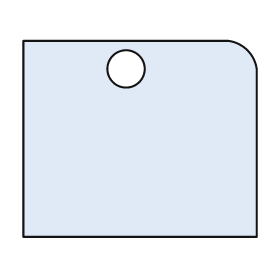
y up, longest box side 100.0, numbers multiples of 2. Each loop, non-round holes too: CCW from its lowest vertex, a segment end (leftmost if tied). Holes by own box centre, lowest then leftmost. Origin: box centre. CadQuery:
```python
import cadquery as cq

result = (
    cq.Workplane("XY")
    .moveTo(-50.0, -42.0)
    .lineTo(50.0, -42.0)
    .lineTo(50.0, 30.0)
    .threePointArc((46.0, 38.0), (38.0, 42.0))
    .lineTo(-50.0, 42.0)
    .close()
    .moveTo(-6.0, 30.0)
    .circle(8.0)
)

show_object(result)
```